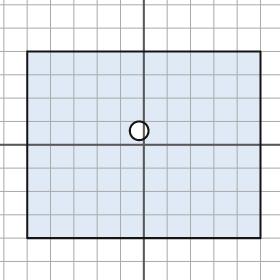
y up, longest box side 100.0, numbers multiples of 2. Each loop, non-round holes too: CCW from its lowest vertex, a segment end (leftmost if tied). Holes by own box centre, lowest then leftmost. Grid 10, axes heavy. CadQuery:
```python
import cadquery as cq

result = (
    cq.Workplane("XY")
    .moveTo(-50.0, -40.0)
    .lineTo(50.0, -40.0)
    .lineTo(50.0, 40.0)
    .lineTo(-50.0, 40.0)
    .close()
    .moveTo(-2.0, 6.0)
    .circle(4.0)
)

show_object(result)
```